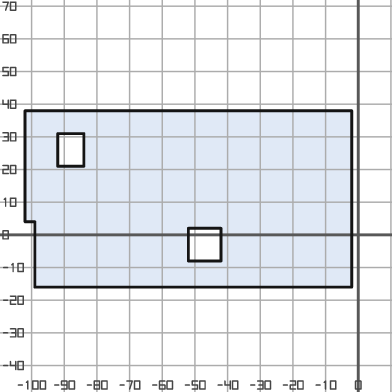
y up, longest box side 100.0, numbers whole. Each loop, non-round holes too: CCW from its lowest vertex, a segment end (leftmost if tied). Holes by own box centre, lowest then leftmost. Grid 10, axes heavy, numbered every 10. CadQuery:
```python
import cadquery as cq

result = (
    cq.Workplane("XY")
    .moveTo(-99.0, -16.0)
    .lineTo(-2.0, -16.0)
    .lineTo(-2.0, 38.0)
    .lineTo(-102.0, 38.0)
    .lineTo(-102.0, 4.0)
    .lineTo(-99.0, 4.0)
    .close()
    .moveTo(-52.0, -8.0)
    .lineTo(-42.0, -8.0)
    .lineTo(-42.0, 2.0)
    .lineTo(-52.0, 2.0)
    .close()
    .moveTo(-92.0, 21.0)
    .lineTo(-84.0, 21.0)
    .lineTo(-84.0, 31.0)
    .lineTo(-92.0, 31.0)
    .close()
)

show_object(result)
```